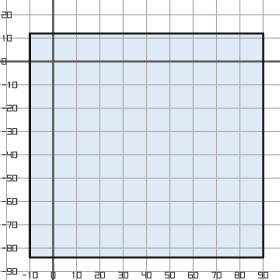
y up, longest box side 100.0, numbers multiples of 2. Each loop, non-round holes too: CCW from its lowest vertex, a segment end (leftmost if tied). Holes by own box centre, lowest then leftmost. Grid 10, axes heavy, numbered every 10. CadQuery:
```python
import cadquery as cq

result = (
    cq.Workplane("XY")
    .moveTo(-10.0, -84.0)
    .lineTo(90.0, -84.0)
    .lineTo(90.0, 12.0)
    .lineTo(-10.0, 12.0)
    .close()
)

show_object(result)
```